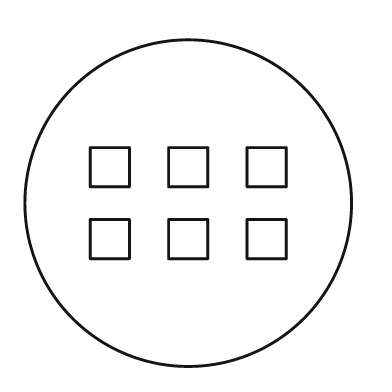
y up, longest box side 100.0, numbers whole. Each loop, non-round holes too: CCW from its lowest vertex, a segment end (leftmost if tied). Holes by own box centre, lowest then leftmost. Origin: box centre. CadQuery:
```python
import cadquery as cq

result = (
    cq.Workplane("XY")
    .moveTo(0.0, 0.0)
    .circle(50.0)
    .moveTo(-30.0, -17.0)
    .lineTo(-18.0, -17.0)
    .lineTo(-18.0, -5.0)
    .lineTo(-30.0, -5.0)
    .close()
    .moveTo(-6.0, -17.0)
    .lineTo(6.0, -17.0)
    .lineTo(6.0, -5.0)
    .lineTo(-6.0, -5.0)
    .close()
    .moveTo(18.0, -17.0)
    .lineTo(30.0, -17.0)
    .lineTo(30.0, -5.0)
    .lineTo(18.0, -5.0)
    .close()
    .moveTo(-30.0, 5.0)
    .lineTo(-18.0, 5.0)
    .lineTo(-18.0, 17.0)
    .lineTo(-30.0, 17.0)
    .close()
    .moveTo(-6.0, 5.0)
    .lineTo(6.0, 5.0)
    .lineTo(6.0, 17.0)
    .lineTo(-6.0, 17.0)
    .close()
    .moveTo(18.0, 5.0)
    .lineTo(30.0, 5.0)
    .lineTo(30.0, 17.0)
    .lineTo(18.0, 17.0)
    .close()
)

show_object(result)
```